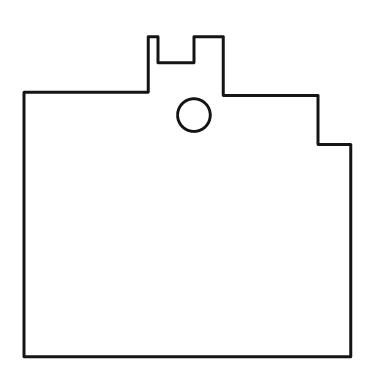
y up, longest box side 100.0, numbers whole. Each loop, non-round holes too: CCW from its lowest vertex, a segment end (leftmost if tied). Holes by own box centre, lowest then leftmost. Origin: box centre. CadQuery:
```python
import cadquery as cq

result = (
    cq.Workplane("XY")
    .moveTo(-50.0, -49.0)
    .lineTo(50.0, -49.0)
    .lineTo(50.0, 16.0)
    .lineTo(40.0, 16.0)
    .lineTo(40.0, 31.0)
    .lineTo(11.0, 31.0)
    .lineTo(11.0, 49.0)
    .lineTo(2.0, 49.0)
    .lineTo(2.0, 41.0)
    .lineTo(-9.0, 41.0)
    .lineTo(-9.0, 49.0)
    .lineTo(-12.0, 49.0)
    .lineTo(-12.0, 32.0)
    .lineTo(-50.0, 32.0)
    .close()
    .moveTo(2.0, 25.0)
    .circle(5.0)
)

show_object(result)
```